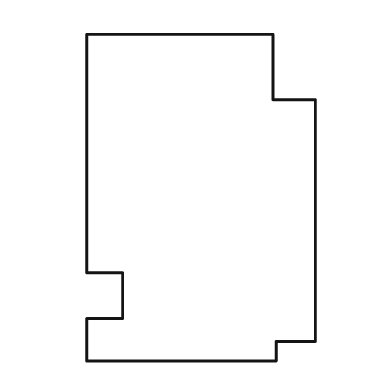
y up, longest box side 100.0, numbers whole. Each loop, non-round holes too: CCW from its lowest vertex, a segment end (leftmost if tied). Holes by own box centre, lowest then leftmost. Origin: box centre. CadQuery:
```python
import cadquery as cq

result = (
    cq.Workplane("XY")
    .moveTo(-35.0, -50.0)
    .lineTo(23.0, -50.0)
    .lineTo(23.0, -44.0)
    .lineTo(35.0, -44.0)
    .lineTo(35.0, 30.0)
    .lineTo(22.0, 30.0)
    .lineTo(22.0, 50.0)
    .lineTo(-35.0, 50.0)
    .lineTo(-35.0, -23.0)
    .lineTo(-24.0, -23.0)
    .lineTo(-24.0, -37.0)
    .lineTo(-35.0, -37.0)
    .close()
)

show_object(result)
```